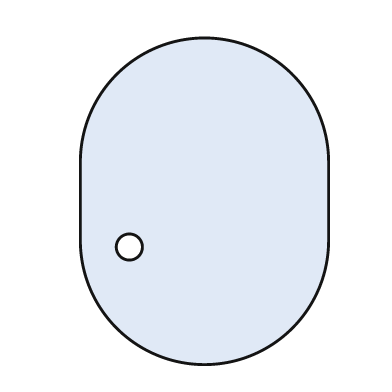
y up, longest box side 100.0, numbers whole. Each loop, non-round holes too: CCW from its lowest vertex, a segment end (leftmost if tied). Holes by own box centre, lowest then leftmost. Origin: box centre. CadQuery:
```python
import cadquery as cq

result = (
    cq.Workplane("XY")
    .moveTo(-38.0, -12.0)
    .threePointArc((0.0, -50.0), (38.0, -12.0))
    .lineTo(38.0, 12.0)
    .threePointArc((0.0, 50.0), (-38.0, 12.0))
    .close()
    .moveTo(-23.0, -14.0)
    .circle(4.0)
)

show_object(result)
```